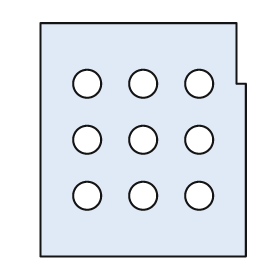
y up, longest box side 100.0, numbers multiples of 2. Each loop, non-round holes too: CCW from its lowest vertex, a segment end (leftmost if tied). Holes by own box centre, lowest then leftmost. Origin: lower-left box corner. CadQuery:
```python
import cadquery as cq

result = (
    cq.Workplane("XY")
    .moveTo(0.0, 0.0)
    .lineTo(88.0, 0.0)
    .lineTo(88.0, 74.0)
    .lineTo(84.0, 74.0)
    .lineTo(84.0, 100.0)
    .lineTo(0.0, 100.0)
    .close()
    .moveTo(20.0, 26.0)
    .circle(6.0)
    .moveTo(44.0, 26.0)
    .circle(6.0)
    .moveTo(68.0, 26.0)
    .circle(6.0)
    .moveTo(20.0, 50.0)
    .circle(6.0)
    .moveTo(44.0, 50.0)
    .circle(6.0)
    .moveTo(68.0, 50.0)
    .circle(6.0)
    .moveTo(20.0, 74.0)
    .circle(6.0)
    .moveTo(44.0, 74.0)
    .circle(6.0)
    .moveTo(68.0, 74.0)
    .circle(6.0)
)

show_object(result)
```